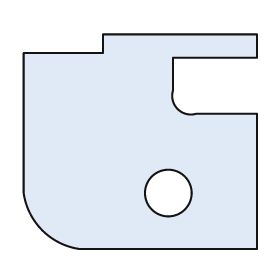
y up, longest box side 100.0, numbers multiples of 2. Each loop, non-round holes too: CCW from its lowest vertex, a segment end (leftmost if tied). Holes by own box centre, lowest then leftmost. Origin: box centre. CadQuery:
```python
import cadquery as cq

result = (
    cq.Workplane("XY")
    .moveTo(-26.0, -46.0)
    .lineTo(50.0, -46.0)
    .lineTo(50.0, 12.0)
    .lineTo(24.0, 12.0)
    .threePointArc((16.0, 14.0), (14.0, 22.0))
    .lineTo(14.0, 36.0)
    .lineTo(50.0, 36.0)
    .lineTo(50.0, 46.0)
    .lineTo(-16.0, 46.0)
    .lineTo(-16.0, 38.0)
    .lineTo(-50.0, 38.0)
    .lineTo(-50.0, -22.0)
    .threePointArc((-42.0, -38.0), (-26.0, -46.0))
    .close()
    .moveTo(12.0, -22.0)
    .circle(10.0)
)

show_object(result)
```